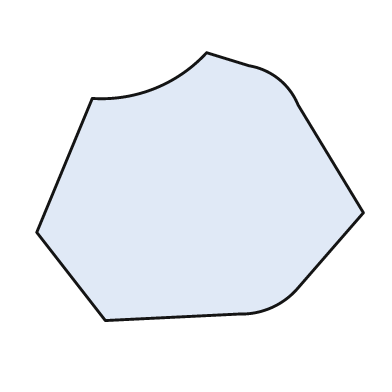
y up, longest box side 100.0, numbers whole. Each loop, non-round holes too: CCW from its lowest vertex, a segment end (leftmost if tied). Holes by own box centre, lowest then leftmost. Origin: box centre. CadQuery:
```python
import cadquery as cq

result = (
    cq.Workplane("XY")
    .moveTo(-29.0, -41.0)
    .lineTo(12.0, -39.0)
    .threePointArc((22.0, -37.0), (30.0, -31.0))
    .lineTo(50.0, -8.0)
    .lineTo(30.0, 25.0)
    .threePointArc((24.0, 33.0), (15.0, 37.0))
    .lineTo(2.0, 41.0)
    .threePointArc((-14.0, 30.0), (-33.0, 27.0))
    .lineTo(-50.0, -14.0)
    .close()
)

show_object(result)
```